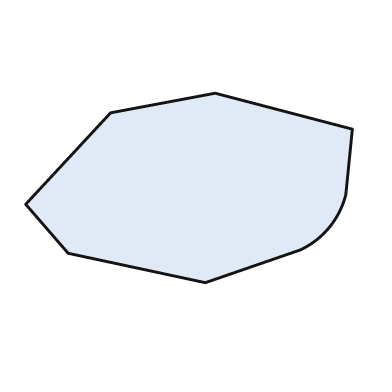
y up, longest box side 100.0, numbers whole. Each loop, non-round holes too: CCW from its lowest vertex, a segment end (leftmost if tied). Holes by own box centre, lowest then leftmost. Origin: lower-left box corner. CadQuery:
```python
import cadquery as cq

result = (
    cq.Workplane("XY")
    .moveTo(55.0, 0.0)
    .lineTo(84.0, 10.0)
    .threePointArc((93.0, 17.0), (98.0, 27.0))
    .lineTo(100.0, 47.0)
    .lineTo(58.0, 58.0)
    .lineTo(26.0, 52.0)
    .lineTo(0.0, 24.0)
    .lineTo(13.0, 9.0)
    .close()
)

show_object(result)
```